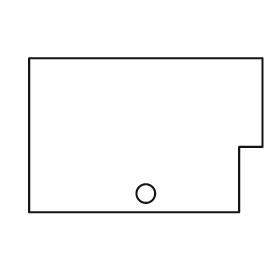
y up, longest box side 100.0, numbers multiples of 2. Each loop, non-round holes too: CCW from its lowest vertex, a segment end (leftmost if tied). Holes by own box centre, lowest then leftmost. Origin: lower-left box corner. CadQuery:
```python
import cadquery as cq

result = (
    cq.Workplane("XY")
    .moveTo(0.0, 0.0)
    .lineTo(90.0, 0.0)
    .lineTo(90.0, 28.0)
    .lineTo(100.0, 28.0)
    .lineTo(100.0, 66.0)
    .lineTo(0.0, 66.0)
    .close()
    .moveTo(50.0, 8.0)
    .circle(4.0)
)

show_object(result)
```